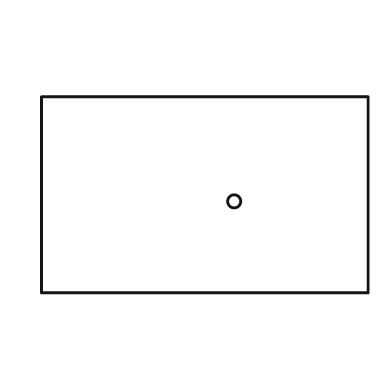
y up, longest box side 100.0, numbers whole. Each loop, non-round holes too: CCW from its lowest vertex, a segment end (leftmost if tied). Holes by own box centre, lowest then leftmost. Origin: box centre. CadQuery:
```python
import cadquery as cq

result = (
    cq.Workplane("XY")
    .moveTo(-50.0, -30.0)
    .lineTo(50.0, -30.0)
    .lineTo(50.0, 30.0)
    .lineTo(-50.0, 30.0)
    .close()
    .moveTo(9.0, -2.0)
    .circle(2.0)
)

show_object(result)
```